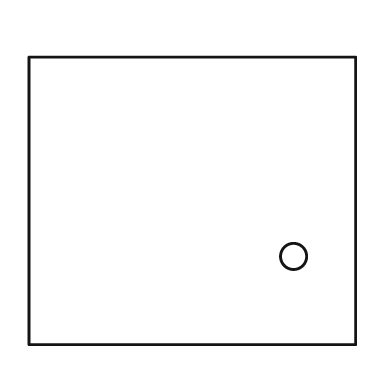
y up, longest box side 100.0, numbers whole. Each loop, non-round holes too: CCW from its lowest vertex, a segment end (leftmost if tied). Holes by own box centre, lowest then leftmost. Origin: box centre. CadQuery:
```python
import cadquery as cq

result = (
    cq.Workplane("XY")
    .moveTo(-50.0, -44.0)
    .lineTo(50.0, -44.0)
    .lineTo(50.0, 44.0)
    .lineTo(-50.0, 44.0)
    .close()
    .moveTo(31.0, -17.0)
    .circle(4.0)
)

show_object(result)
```